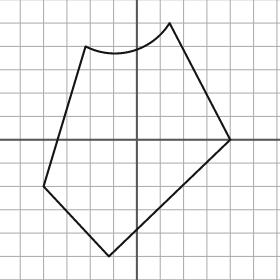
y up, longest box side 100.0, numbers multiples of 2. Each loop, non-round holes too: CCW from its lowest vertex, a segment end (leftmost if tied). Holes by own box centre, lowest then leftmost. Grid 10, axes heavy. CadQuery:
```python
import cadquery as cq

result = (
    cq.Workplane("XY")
    .moveTo(-12.0, -50.0)
    .lineTo(40.0, 0.0)
    .lineTo(14.0, 50.0)
    .threePointArc((-2.0, 38.0), (-22.0, 40.0))
    .lineTo(-40.0, -20.0)
    .close()
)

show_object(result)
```